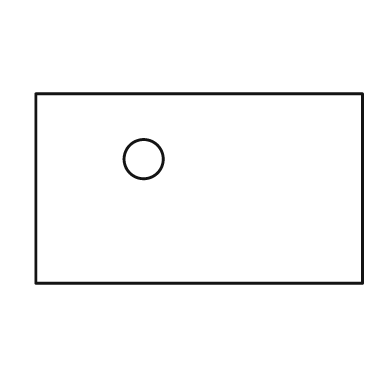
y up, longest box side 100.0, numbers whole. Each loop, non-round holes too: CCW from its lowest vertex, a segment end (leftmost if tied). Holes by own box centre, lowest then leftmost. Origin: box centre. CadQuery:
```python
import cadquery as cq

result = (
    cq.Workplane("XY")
    .moveTo(-50.0, -29.0)
    .lineTo(50.0, -29.0)
    .lineTo(50.0, 29.0)
    .lineTo(-50.0, 29.0)
    .close()
    .moveTo(-17.0, 9.0)
    .circle(6.0)
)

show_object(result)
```